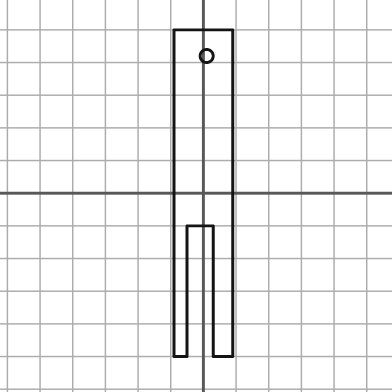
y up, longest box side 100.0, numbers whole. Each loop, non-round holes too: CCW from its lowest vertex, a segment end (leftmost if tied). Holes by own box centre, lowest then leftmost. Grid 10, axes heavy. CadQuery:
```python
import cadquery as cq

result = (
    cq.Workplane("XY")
    .moveTo(-9.0, -50.0)
    .lineTo(-5.0, -50.0)
    .lineTo(-5.0, -10.0)
    .lineTo(3.0, -10.0)
    .lineTo(3.0, -50.0)
    .lineTo(9.0, -50.0)
    .lineTo(9.0, 50.0)
    .lineTo(-9.0, 50.0)
    .close()
    .moveTo(1.0, 42.0)
    .circle(2.0)
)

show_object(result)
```